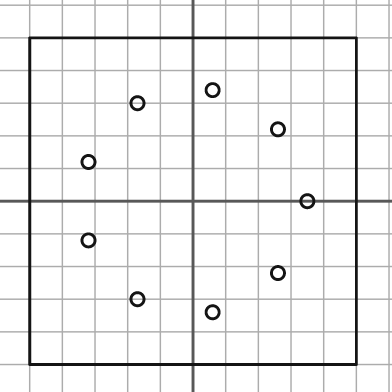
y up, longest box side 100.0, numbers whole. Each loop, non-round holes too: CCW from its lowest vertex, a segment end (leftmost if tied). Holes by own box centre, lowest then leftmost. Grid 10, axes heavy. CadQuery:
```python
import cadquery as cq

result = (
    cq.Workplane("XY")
    .moveTo(-50.0, -50.0)
    .lineTo(50.0, -50.0)
    .lineTo(50.0, 50.0)
    .lineTo(-50.0, 50.0)
    .close()
    .moveTo(6.0, -34.0)
    .circle(2.0)
    .moveTo(-17.0, -30.0)
    .circle(2.0)
    .moveTo(26.0, -22.0)
    .circle(2.0)
    .moveTo(-32.0, -12.0)
    .circle(2.0)
    .moveTo(35.0, 0.0)
    .circle(2.0)
    .moveTo(-32.0, 12.0)
    .circle(2.0)
    .moveTo(26.0, 22.0)
    .circle(2.0)
    .moveTo(-17.0, 30.0)
    .circle(2.0)
    .moveTo(6.0, 34.0)
    .circle(2.0)
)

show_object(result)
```